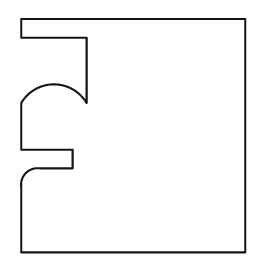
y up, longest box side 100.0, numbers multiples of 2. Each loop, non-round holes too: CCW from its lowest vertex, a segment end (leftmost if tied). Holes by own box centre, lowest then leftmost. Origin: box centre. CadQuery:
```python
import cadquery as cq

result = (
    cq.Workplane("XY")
    .moveTo(-48.0, -50.0)
    .lineTo(48.0, -50.0)
    .lineTo(48.0, 50.0)
    .lineTo(-48.0, 50.0)
    .lineTo(-48.0, 42.0)
    .lineTo(-20.0, 42.0)
    .lineTo(-20.0, 14.0)
    .threePointArc((-34.0, 22.0), (-48.0, 14.0))
    .lineTo(-48.0, -6.0)
    .lineTo(-26.0, -6.0)
    .lineTo(-26.0, -14.0)
    .lineTo(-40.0, -14.0)
    .threePointArc((-46.0, -16.0), (-48.0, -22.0))
    .close()
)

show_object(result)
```